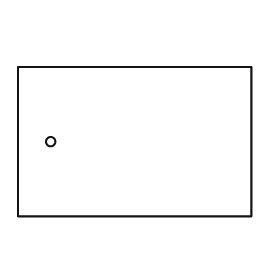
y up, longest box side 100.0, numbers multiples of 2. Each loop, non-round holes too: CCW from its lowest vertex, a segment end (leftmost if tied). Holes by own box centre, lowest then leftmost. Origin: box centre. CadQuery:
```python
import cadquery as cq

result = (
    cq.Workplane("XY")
    .moveTo(-50.0, -32.0)
    .lineTo(50.0, -32.0)
    .lineTo(50.0, 32.0)
    .lineTo(-50.0, 32.0)
    .close()
    .moveTo(-36.0, 0.0)
    .circle(2.0)
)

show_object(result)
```